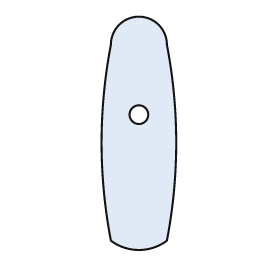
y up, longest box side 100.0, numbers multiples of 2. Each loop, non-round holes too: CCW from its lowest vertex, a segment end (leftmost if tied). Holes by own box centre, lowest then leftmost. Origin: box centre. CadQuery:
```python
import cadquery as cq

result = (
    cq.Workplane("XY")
    .moveTo(-12.0, -46.0)
    .threePointArc((0.0, -50.0), (12.0, -46.0))
    .threePointArc((16.0, -4.0), (12.0, 38.0))
    .threePointArc((0.0, 50.0), (-12.0, 38.0))
    .threePointArc((-16.0, -4.0), (-12.0, -46.0))
    .close()
    .moveTo(0.0, 8.0)
    .circle(4.0)
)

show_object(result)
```